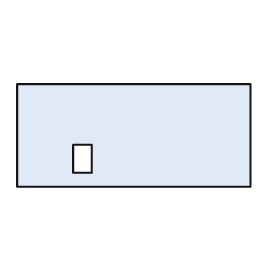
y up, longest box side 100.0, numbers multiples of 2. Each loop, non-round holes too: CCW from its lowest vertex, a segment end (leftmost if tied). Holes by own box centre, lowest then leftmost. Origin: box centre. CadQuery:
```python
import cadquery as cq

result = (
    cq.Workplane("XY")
    .moveTo(-50.0, -22.0)
    .lineTo(50.0, -22.0)
    .lineTo(50.0, 22.0)
    .lineTo(-50.0, 22.0)
    .close()
    .moveTo(-26.0, -16.0)
    .lineTo(-18.0, -16.0)
    .lineTo(-18.0, -4.0)
    .lineTo(-26.0, -4.0)
    .close()
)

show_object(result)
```